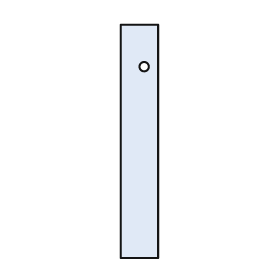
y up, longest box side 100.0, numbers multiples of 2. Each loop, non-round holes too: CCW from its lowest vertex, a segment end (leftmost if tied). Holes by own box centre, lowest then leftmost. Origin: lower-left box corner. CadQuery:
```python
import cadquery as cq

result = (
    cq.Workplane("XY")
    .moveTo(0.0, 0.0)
    .lineTo(16.0, 0.0)
    .lineTo(16.0, 100.0)
    .lineTo(0.0, 100.0)
    .close()
    .moveTo(10.0, 82.0)
    .circle(2.0)
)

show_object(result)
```